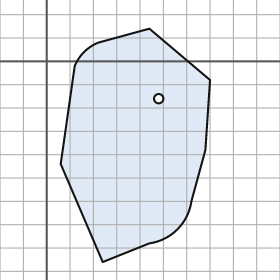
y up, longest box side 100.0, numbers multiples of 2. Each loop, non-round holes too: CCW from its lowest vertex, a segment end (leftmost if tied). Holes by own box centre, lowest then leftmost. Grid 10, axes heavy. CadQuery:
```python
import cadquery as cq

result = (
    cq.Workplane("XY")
    .moveTo(24.0, -86.0)
    .lineTo(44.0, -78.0)
    .threePointArc((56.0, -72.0), (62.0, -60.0))
    .lineTo(68.0, -38.0)
    .lineTo(70.0, -8.0)
    .lineTo(44.0, 14.0)
    .lineTo(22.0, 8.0)
    .threePointArc((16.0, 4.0), (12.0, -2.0))
    .lineTo(6.0, -44.0)
    .close()
    .moveTo(48.0, -16.0)
    .circle(2.0)
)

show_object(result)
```